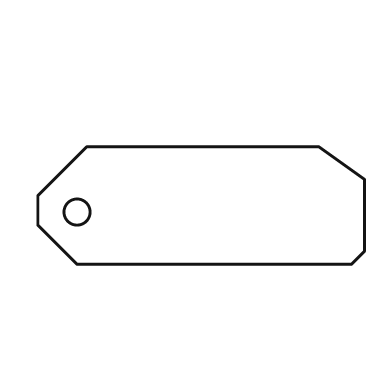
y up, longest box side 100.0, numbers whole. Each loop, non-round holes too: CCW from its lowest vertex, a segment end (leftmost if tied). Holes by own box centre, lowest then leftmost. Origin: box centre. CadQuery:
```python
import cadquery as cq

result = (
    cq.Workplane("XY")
    .moveTo(-38.0, -18.0)
    .lineTo(46.0, -18.0)
    .lineTo(50.0, -14.0)
    .lineTo(50.0, 8.0)
    .lineTo(36.0, 18.0)
    .lineTo(-35.0, 18.0)
    .lineTo(-50.0, 3.0)
    .lineTo(-50.0, -6.0)
    .close()
    .moveTo(-38.0, -2.0)
    .circle(4.0)
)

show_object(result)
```